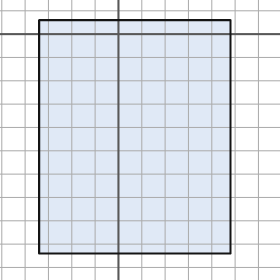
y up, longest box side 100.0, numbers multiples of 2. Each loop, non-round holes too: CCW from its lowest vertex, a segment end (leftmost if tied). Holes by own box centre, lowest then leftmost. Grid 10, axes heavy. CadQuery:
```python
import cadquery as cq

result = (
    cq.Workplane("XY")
    .moveTo(-34.0, -94.0)
    .lineTo(48.0, -94.0)
    .lineTo(48.0, 6.0)
    .lineTo(-34.0, 6.0)
    .close()
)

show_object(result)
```